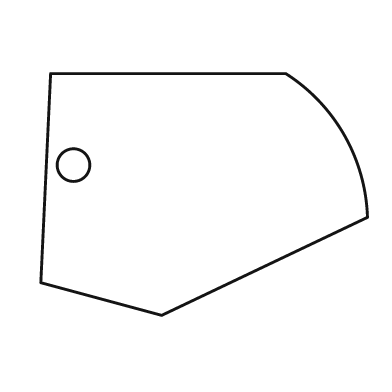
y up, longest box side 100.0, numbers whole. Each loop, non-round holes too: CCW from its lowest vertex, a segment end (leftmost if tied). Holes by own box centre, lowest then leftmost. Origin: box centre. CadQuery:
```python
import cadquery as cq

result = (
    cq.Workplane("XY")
    .moveTo(-13.0, -37.0)
    .lineTo(50.0, -7.0)
    .threePointArc((43.0, 18.0), (25.0, 37.0))
    .lineTo(-47.0, 37.0)
    .lineTo(-50.0, -27.0)
    .close()
    .moveTo(-40.0, 9.0)
    .circle(5.0)
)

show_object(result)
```